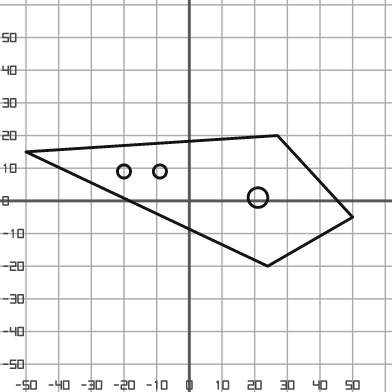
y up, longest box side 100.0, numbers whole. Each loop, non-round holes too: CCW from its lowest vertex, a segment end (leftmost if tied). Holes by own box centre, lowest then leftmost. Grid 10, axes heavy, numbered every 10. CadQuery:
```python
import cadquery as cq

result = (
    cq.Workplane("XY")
    .moveTo(24.0, -20.0)
    .lineTo(50.0, -5.0)
    .lineTo(27.0, 20.0)
    .lineTo(-50.0, 15.0)
    .close()
    .moveTo(21.0, 1.0)
    .circle(3.0)
    .moveTo(-20.0, 9.0)
    .circle(2.0)
    .moveTo(-9.0, 9.0)
    .circle(2.0)
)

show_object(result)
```